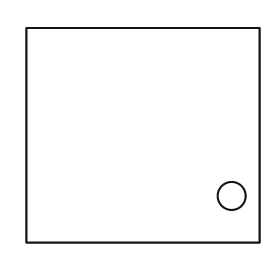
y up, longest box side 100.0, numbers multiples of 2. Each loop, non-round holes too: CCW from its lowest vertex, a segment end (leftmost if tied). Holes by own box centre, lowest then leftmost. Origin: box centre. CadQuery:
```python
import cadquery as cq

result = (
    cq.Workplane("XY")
    .moveTo(-50.0, -46.0)
    .lineTo(50.0, -46.0)
    .lineTo(50.0, 46.0)
    .lineTo(-50.0, 46.0)
    .close()
    .moveTo(38.0, -26.0)
    .circle(6.0)
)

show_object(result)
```